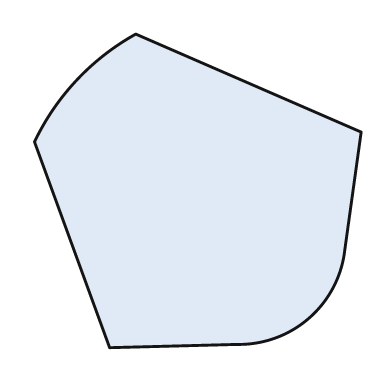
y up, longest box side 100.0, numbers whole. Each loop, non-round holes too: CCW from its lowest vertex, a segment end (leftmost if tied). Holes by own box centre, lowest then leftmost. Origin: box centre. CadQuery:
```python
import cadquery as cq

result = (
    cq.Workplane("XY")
    .moveTo(-27.0, -48.0)
    .lineTo(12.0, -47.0)
    .threePointArc((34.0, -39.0), (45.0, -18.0))
    .lineTo(50.0, 18.0)
    .lineTo(-19.0, 48.0)
    .threePointArc((-37.0, 34.0), (-50.0, 15.0))
    .close()
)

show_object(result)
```